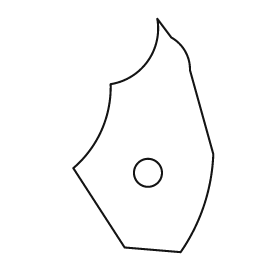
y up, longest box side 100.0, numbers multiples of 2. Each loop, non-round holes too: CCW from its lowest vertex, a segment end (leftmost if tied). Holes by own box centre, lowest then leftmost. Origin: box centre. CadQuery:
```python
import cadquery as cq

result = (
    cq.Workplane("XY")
    .moveTo(16.0, -50.0)
    .threePointArc((26.0, -30.0), (30.0, -8.0))
    .lineTo(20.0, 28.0)
    .threePointArc((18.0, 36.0), (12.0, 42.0))
    .lineTo(6.0, 50.0)
    .threePointArc((2.0, 32.0), (-14.0, 22.0))
    .threePointArc((-18.0, 2.0), (-30.0, -14.0))
    .lineTo(-8.0, -48.0)
    .close()
    .moveTo(2.0, -16.0)
    .circle(6.0)
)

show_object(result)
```